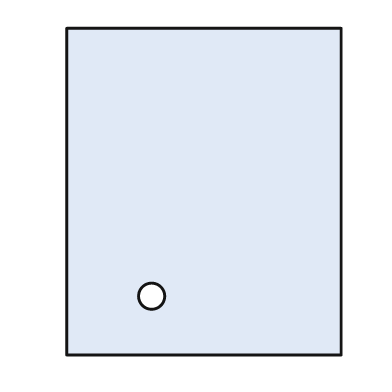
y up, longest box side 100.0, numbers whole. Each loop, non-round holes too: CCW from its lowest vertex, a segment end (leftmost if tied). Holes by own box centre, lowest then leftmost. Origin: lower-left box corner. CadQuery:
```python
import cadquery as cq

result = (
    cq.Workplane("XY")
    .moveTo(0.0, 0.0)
    .lineTo(84.0, 0.0)
    .lineTo(84.0, 100.0)
    .lineTo(0.0, 100.0)
    .close()
    .moveTo(26.0, 18.0)
    .circle(4.0)
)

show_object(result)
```